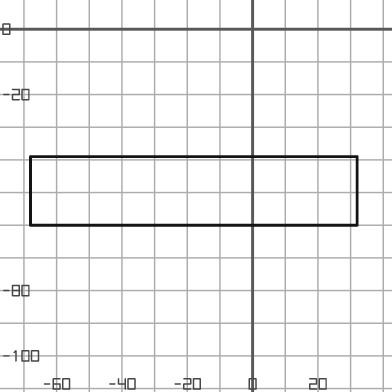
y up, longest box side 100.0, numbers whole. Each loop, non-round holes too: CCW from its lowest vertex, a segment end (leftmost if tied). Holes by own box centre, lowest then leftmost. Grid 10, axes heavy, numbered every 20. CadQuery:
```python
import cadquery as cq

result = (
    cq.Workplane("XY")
    .moveTo(-68.0, -60.0)
    .lineTo(32.0, -60.0)
    .lineTo(32.0, -39.0)
    .lineTo(-68.0, -39.0)
    .close()
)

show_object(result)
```